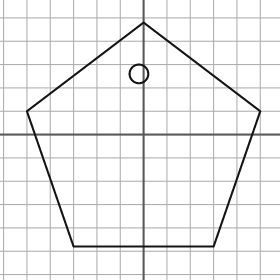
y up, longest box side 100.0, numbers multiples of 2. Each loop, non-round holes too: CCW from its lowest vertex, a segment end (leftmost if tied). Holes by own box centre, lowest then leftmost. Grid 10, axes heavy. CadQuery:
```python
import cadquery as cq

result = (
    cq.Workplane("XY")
    .moveTo(-30.0, -48.0)
    .lineTo(30.0, -48.0)
    .lineTo(50.0, 10.0)
    .lineTo(0.0, 48.0)
    .lineTo(-50.0, 10.0)
    .close()
    .moveTo(-2.0, 26.0)
    .circle(4.0)
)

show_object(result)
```